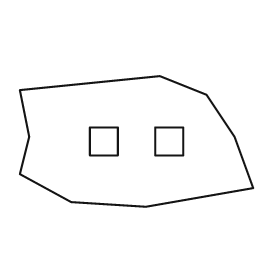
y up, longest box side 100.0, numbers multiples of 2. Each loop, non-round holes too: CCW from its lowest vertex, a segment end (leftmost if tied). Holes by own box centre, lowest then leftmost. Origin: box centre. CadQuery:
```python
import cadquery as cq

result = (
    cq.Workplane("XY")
    .moveTo(4.0, -28.0)
    .lineTo(50.0, -20.0)
    .lineTo(42.0, 2.0)
    .lineTo(30.0, 20.0)
    .lineTo(10.0, 28.0)
    .lineTo(-50.0, 22.0)
    .lineTo(-46.0, 2.0)
    .lineTo(-50.0, -14.0)
    .lineTo(-28.0, -26.0)
    .close()
    .moveTo(-20.0, -6.0)
    .lineTo(-8.0, -6.0)
    .lineTo(-8.0, 6.0)
    .lineTo(-20.0, 6.0)
    .close()
    .moveTo(8.0, -6.0)
    .lineTo(20.0, -6.0)
    .lineTo(20.0, 6.0)
    .lineTo(8.0, 6.0)
    .close()
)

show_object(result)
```